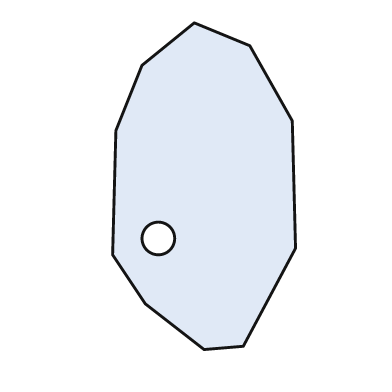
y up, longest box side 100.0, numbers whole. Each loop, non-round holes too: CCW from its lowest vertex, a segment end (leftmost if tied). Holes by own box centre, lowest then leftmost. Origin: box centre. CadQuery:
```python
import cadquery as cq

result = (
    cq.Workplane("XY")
    .moveTo(0.0, -50.0)
    .lineTo(12.0, -49.0)
    .lineTo(28.0, -19.0)
    .lineTo(27.0, 20.0)
    .lineTo(14.0, 43.0)
    .lineTo(-3.0, 50.0)
    .lineTo(-19.0, 37.0)
    .lineTo(-27.0, 17.0)
    .lineTo(-28.0, -21.0)
    .lineTo(-18.0, -36.0)
    .close()
    .moveTo(-14.0, -16.0)
    .circle(5.0)
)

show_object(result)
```